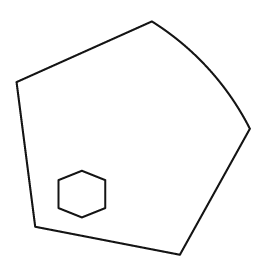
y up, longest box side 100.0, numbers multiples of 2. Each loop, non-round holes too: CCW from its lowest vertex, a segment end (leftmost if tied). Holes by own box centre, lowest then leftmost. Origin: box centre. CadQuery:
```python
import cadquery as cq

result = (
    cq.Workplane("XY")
    .moveTo(20.0, -50.0)
    .lineTo(50.0, 4.0)
    .threePointArc((32.0, 30.0), (8.0, 50.0))
    .lineTo(-50.0, 24.0)
    .lineTo(-42.0, -38.0)
    .close()
    .moveTo(-22.0, -34.0)
    .lineTo(-12.0, -30.0)
    .lineTo(-12.0, -18.0)
    .lineTo(-22.0, -14.0)
    .lineTo(-32.0, -18.0)
    .lineTo(-32.0, -30.0)
    .close()
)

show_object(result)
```